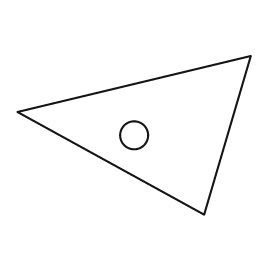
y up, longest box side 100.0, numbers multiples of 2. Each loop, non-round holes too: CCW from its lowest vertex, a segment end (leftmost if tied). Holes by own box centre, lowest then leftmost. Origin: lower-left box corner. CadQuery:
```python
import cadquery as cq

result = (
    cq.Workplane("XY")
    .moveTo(80.0, 0.0)
    .lineTo(100.0, 68.0)
    .lineTo(0.0, 44.0)
    .close()
    .moveTo(50.0, 34.0)
    .circle(6.0)
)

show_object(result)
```